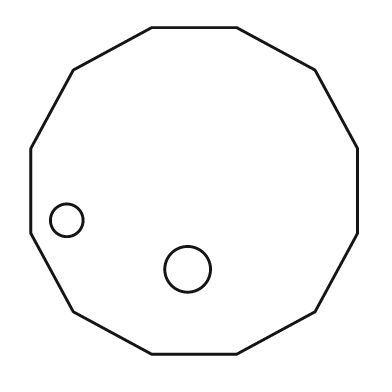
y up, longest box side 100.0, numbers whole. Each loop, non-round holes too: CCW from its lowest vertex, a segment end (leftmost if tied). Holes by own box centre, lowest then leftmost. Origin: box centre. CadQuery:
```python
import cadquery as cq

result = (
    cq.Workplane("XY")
    .moveTo(-13.0, -50.0)
    .lineTo(13.0, -50.0)
    .lineTo(37.0, -37.0)
    .lineTo(50.0, -13.0)
    .lineTo(50.0, 13.0)
    .lineTo(37.0, 37.0)
    .lineTo(13.0, 50.0)
    .lineTo(-13.0, 50.0)
    .lineTo(-37.0, 37.0)
    .lineTo(-50.0, 13.0)
    .lineTo(-50.0, -13.0)
    .lineTo(-37.0, -37.0)
    .close()
    .moveTo(-2.0, -24.0)
    .circle(7.0)
    .moveTo(-39.0, -9.0)
    .circle(5.0)
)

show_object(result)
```